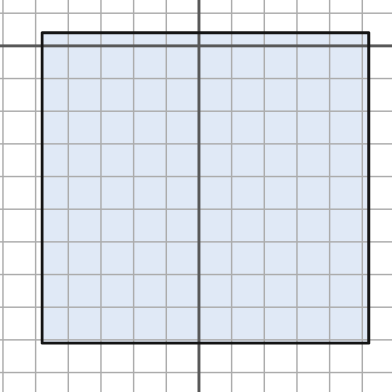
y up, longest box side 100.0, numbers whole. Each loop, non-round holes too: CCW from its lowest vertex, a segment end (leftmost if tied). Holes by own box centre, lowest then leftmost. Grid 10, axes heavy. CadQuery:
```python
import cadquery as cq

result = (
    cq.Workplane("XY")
    .moveTo(-48.0, -91.0)
    .lineTo(52.0, -91.0)
    .lineTo(52.0, 4.0)
    .lineTo(-48.0, 4.0)
    .close()
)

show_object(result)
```